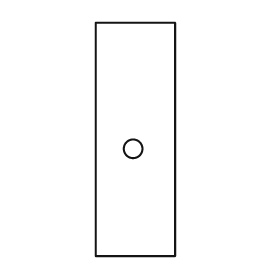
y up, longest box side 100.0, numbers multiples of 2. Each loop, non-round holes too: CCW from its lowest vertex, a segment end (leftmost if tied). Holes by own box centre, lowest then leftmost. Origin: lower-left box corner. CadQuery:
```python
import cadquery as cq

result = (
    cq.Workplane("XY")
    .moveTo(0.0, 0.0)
    .lineTo(34.0, 0.0)
    .lineTo(34.0, 100.0)
    .lineTo(0.0, 100.0)
    .close()
    .moveTo(16.0, 46.0)
    .circle(4.0)
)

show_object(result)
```